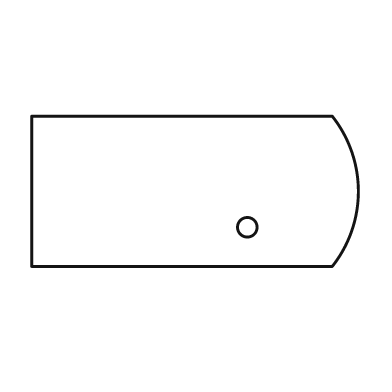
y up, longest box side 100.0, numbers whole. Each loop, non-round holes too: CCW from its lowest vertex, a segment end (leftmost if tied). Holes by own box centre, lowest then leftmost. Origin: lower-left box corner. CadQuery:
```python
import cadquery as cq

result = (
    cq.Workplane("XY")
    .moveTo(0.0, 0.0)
    .lineTo(92.0, 0.0)
    .threePointArc((100.0, 23.0), (92.0, 46.0))
    .lineTo(0.0, 46.0)
    .close()
    .moveTo(66.0, 12.0)
    .circle(3.0)
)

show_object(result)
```